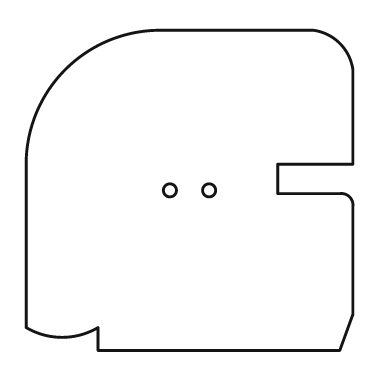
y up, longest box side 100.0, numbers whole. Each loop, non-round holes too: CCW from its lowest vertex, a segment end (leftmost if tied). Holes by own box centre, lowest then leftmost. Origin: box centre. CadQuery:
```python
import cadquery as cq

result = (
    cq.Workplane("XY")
    .moveTo(-28.0, -49.0)
    .lineTo(46.0, -49.0)
    .lineTo(50.0, -38.0)
    .lineTo(50.0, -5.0)
    .threePointArc((49.0, -2.0), (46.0, -1.0))
    .lineTo(27.0, -1.0)
    .lineTo(27.0, 8.0)
    .lineTo(50.0, 8.0)
    .lineTo(50.0, 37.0)
    .threePointArc((46.0, 45.0), (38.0, 49.0))
    .lineTo(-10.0, 49.0)
    .threePointArc((-38.0, 37.0), (-50.0, 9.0))
    .lineTo(-50.0, -42.0)
    .threePointArc((-39.0, -45.0), (-28.0, -42.0))
    .close()
    .moveTo(-6.0, 0.0)
    .circle(2.0)
    .moveTo(6.0, 0.0)
    .circle(2.0)
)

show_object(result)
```